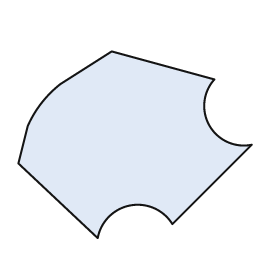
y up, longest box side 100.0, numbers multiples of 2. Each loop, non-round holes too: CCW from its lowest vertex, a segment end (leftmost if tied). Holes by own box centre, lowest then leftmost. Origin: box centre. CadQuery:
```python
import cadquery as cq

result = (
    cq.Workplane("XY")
    .moveTo(-16.0, -40.0)
    .threePointArc((-2.0, -26.0), (16.0, -34.0))
    .lineTo(50.0, 0.0)
    .threePointArc((32.0, 8.0), (34.0, 28.0))
    .lineTo(-10.0, 40.0)
    .lineTo(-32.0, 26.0)
    .threePointArc((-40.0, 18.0), (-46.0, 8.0))
    .lineTo(-50.0, -8.0)
    .close()
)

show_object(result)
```